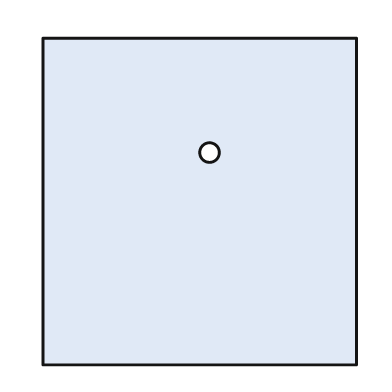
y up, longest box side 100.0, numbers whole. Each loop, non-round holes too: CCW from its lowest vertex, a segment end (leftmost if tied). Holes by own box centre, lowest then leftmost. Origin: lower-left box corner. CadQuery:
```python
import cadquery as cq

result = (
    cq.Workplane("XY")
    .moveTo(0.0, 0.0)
    .lineTo(96.0, 0.0)
    .lineTo(96.0, 100.0)
    .lineTo(0.0, 100.0)
    .close()
    .moveTo(51.0, 65.0)
    .circle(3.0)
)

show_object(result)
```